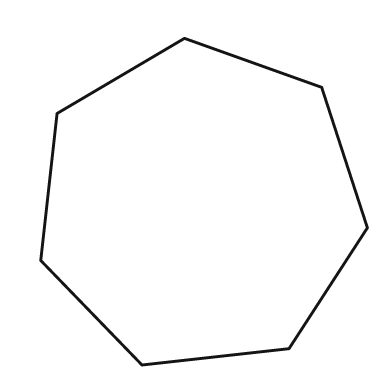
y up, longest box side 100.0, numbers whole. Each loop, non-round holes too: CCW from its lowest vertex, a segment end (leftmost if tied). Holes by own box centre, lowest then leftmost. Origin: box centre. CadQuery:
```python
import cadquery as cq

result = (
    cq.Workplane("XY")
    .moveTo(-19.0, -50.0)
    .lineTo(26.0, -45.0)
    .lineTo(50.0, -8.0)
    .lineTo(36.0, 35.0)
    .lineTo(-6.0, 50.0)
    .lineTo(-45.0, 27.0)
    .lineTo(-50.0, -18.0)
    .close()
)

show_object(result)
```